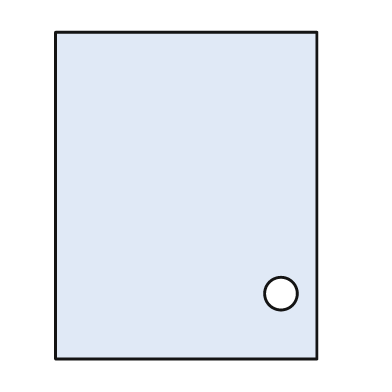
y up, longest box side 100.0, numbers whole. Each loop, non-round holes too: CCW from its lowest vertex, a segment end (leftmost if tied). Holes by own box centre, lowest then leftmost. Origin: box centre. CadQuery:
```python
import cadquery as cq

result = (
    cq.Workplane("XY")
    .moveTo(-40.0, -50.0)
    .lineTo(40.0, -50.0)
    .lineTo(40.0, 50.0)
    .lineTo(-40.0, 50.0)
    .close()
    .moveTo(29.0, -30.0)
    .circle(5.0)
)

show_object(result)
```